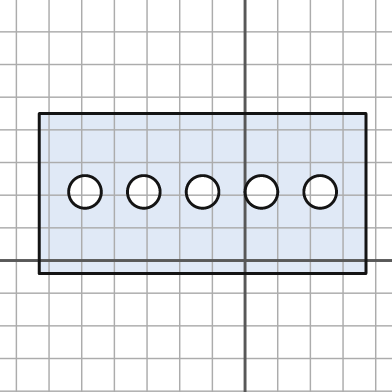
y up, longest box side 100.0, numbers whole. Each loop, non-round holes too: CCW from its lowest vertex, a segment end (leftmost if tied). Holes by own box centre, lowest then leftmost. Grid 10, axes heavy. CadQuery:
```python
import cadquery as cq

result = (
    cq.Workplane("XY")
    .moveTo(-63.0, -4.0)
    .lineTo(37.0, -4.0)
    .lineTo(37.0, 45.0)
    .lineTo(-63.0, 45.0)
    .close()
    .moveTo(-49.0, 21.0)
    .circle(5.0)
    .moveTo(-31.0, 21.0)
    .circle(5.0)
    .moveTo(-13.0, 21.0)
    .circle(5.0)
    .moveTo(5.0, 21.0)
    .circle(5.0)
    .moveTo(23.0, 21.0)
    .circle(5.0)
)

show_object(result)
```